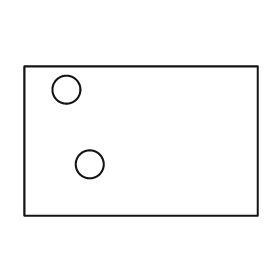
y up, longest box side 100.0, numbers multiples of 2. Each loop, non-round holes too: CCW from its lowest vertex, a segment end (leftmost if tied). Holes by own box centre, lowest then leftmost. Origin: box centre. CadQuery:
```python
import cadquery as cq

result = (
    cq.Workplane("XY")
    .moveTo(-50.0, -32.0)
    .lineTo(50.0, -32.0)
    .lineTo(50.0, 32.0)
    .lineTo(-50.0, 32.0)
    .close()
    .moveTo(-22.0, -10.0)
    .circle(6.0)
    .moveTo(-32.0, 22.0)
    .circle(6.0)
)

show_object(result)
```